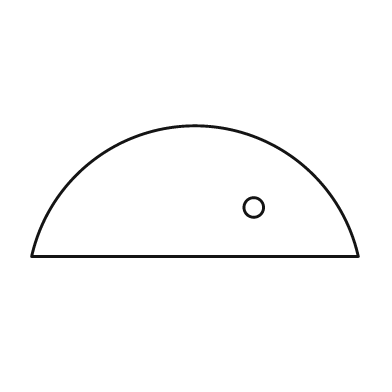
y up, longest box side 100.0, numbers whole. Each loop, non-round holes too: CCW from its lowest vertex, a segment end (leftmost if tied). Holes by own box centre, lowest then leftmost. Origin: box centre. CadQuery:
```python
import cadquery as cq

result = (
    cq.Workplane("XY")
    .moveTo(-50.0, -20.0)
    .lineTo(50.0, -20.0)
    .threePointArc((0.0, 20.0), (-50.0, -20.0))
    .close()
    .moveTo(18.0, -5.0)
    .circle(3.0)
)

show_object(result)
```